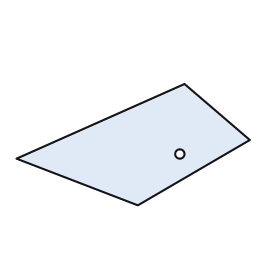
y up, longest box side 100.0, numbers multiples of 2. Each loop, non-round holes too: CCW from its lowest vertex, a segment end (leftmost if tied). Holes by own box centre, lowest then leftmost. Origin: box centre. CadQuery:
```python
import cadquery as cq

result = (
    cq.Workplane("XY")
    .moveTo(2.0, -26.0)
    .lineTo(50.0, 2.0)
    .lineTo(22.0, 26.0)
    .lineTo(-50.0, -6.0)
    .close()
    .moveTo(20.0, -4.0)
    .circle(2.0)
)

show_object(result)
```